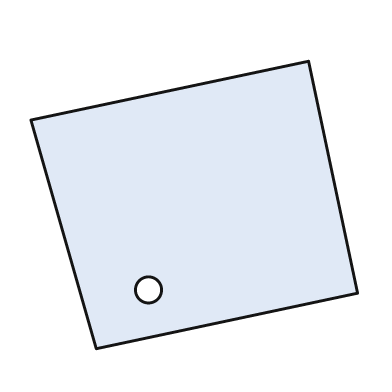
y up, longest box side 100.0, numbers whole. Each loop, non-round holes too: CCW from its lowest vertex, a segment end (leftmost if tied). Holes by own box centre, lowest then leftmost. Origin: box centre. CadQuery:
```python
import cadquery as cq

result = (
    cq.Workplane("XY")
    .moveTo(-30.0, -44.0)
    .lineTo(50.0, -27.0)
    .lineTo(35.0, 44.0)
    .lineTo(-50.0, 26.0)
    .close()
    .moveTo(-14.0, -26.0)
    .circle(4.0)
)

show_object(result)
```